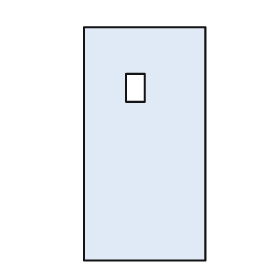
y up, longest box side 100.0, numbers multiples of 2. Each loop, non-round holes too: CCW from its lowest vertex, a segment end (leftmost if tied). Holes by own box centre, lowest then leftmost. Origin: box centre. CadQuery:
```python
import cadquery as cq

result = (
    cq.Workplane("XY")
    .moveTo(-26.0, -50.0)
    .lineTo(26.0, -50.0)
    .lineTo(26.0, 50.0)
    .lineTo(-26.0, 50.0)
    .close()
    .moveTo(-8.0, 18.0)
    .lineTo(0.0, 18.0)
    .lineTo(0.0, 30.0)
    .lineTo(-8.0, 30.0)
    .close()
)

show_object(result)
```